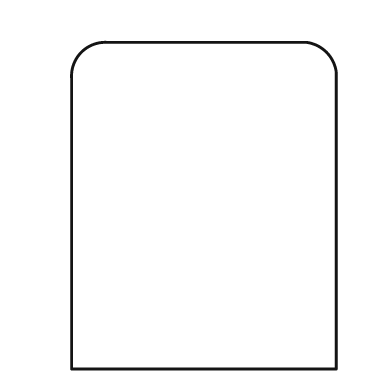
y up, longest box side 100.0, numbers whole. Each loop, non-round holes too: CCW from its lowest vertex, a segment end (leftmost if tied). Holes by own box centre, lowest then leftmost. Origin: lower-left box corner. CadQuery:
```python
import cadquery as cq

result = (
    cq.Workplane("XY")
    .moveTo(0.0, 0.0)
    .lineTo(81.0, 0.0)
    .lineTo(81.0, 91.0)
    .threePointArc((78.0, 97.0), (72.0, 100.0))
    .lineTo(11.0, 100.0)
    .threePointArc((3.0, 97.0), (0.0, 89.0))
    .close()
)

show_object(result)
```